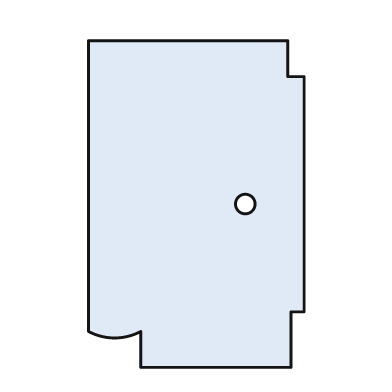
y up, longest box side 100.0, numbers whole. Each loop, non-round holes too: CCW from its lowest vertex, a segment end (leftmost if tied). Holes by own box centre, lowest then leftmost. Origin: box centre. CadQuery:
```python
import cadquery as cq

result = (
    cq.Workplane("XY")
    .moveTo(-17.0, -50.0)
    .lineTo(29.0, -50.0)
    .lineTo(29.0, -33.0)
    .lineTo(33.0, -33.0)
    .lineTo(33.0, 39.0)
    .lineTo(28.0, 39.0)
    .lineTo(28.0, 50.0)
    .lineTo(-33.0, 50.0)
    .lineTo(-33.0, -39.0)
    .threePointArc((-25.0, -41.0), (-17.0, -39.0))
    .close()
    .moveTo(15.0, 0.0)
    .circle(3.0)
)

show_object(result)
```